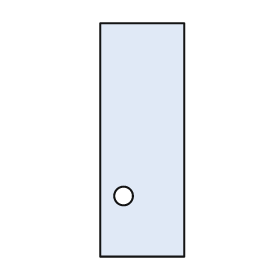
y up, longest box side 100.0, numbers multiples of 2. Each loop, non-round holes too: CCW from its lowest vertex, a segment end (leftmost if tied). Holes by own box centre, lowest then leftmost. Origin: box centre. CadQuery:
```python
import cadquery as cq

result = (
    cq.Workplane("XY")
    .moveTo(-18.0, -50.0)
    .lineTo(18.0, -50.0)
    .lineTo(18.0, 50.0)
    .lineTo(-18.0, 50.0)
    .close()
    .moveTo(-8.0, -24.0)
    .circle(4.0)
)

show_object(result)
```